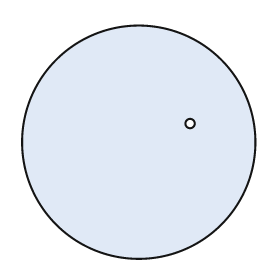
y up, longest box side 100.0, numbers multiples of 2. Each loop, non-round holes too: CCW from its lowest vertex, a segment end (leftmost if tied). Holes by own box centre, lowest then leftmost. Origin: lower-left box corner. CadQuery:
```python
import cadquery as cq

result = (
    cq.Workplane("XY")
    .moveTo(50.0, 50.0)
    .circle(50.0)
    .moveTo(72.0, 58.0)
    .circle(2.0)
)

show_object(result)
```